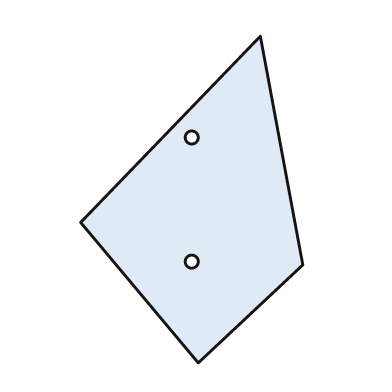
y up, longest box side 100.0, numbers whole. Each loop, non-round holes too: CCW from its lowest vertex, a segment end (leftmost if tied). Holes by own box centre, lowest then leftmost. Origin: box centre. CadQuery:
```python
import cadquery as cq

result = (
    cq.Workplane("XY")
    .moveTo(2.0, -50.0)
    .lineTo(34.0, -20.0)
    .lineTo(21.0, 50.0)
    .lineTo(-34.0, -7.0)
    .close()
    .moveTo(0.0, -19.0)
    .circle(2.0)
    .moveTo(0.0, 19.0)
    .circle(2.0)
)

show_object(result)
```